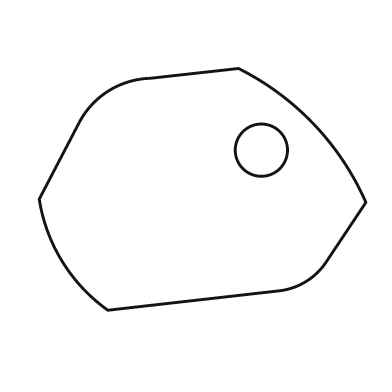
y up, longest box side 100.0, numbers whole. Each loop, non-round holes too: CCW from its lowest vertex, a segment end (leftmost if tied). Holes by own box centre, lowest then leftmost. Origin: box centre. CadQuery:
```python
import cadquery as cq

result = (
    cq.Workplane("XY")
    .moveTo(-29.0, -37.0)
    .lineTo(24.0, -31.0)
    .threePointArc((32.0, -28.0), (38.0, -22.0))
    .lineTo(50.0, -4.0)
    .threePointArc((34.0, 20.0), (11.0, 37.0))
    .lineTo(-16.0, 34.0)
    .threePointArc((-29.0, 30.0), (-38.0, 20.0))
    .lineTo(-50.0, -3.0)
    .threePointArc((-43.0, -22.0), (-29.0, -37.0))
    .close()
    .moveTo(18.0, 12.0)
    .circle(8.0)
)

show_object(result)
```